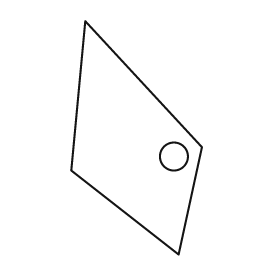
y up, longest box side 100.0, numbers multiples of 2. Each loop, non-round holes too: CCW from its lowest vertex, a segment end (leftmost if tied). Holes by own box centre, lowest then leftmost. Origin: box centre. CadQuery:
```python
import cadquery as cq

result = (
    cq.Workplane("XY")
    .moveTo(18.0, -50.0)
    .lineTo(28.0, -4.0)
    .lineTo(-22.0, 50.0)
    .lineTo(-28.0, -14.0)
    .close()
    .moveTo(16.0, -8.0)
    .circle(6.0)
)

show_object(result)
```